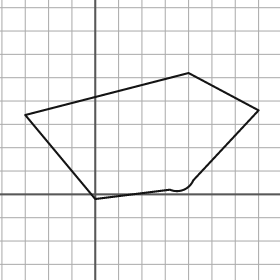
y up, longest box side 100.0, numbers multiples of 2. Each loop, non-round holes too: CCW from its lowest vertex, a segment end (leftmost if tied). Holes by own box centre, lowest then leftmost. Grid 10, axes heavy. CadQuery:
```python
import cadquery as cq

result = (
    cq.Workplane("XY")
    .moveTo(0.0, -2.0)
    .lineTo(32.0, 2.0)
    .threePointArc((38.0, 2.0), (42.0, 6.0))
    .lineTo(70.0, 36.0)
    .lineTo(40.0, 52.0)
    .lineTo(-30.0, 34.0)
    .close()
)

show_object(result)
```